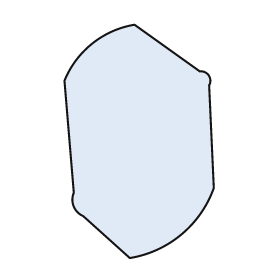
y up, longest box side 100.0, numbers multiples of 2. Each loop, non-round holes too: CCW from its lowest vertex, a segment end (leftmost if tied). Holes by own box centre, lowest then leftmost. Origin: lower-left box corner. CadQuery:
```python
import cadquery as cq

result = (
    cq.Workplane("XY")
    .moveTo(28.0, 0.0)
    .threePointArc((50.0, 10.0), (64.0, 30.0))
    .lineTo(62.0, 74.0)
    .threePointArc((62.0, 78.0), (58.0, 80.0))
    .lineTo(30.0, 100.0)
    .threePointArc((12.0, 92.0), (0.0, 76.0))
    .lineTo(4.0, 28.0)
    .threePointArc((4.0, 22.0), (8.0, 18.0))
    .close()
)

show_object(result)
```